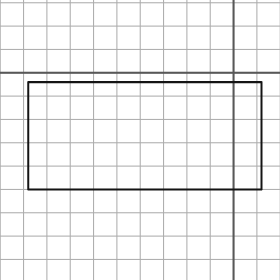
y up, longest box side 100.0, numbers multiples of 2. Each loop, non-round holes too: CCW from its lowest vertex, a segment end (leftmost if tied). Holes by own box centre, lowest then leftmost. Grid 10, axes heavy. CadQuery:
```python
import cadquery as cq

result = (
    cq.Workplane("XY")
    .moveTo(-88.0, -50.0)
    .lineTo(12.0, -50.0)
    .lineTo(12.0, -4.0)
    .lineTo(-88.0, -4.0)
    .close()
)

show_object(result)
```